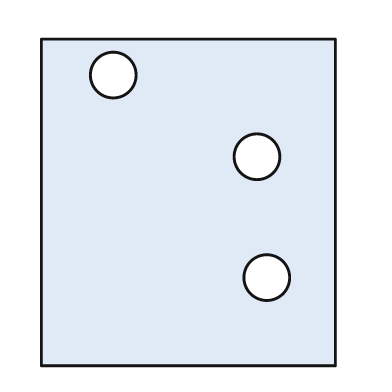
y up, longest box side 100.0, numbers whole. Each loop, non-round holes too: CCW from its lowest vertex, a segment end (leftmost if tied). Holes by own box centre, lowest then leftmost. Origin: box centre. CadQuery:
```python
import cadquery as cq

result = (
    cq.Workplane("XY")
    .moveTo(-45.0, -50.0)
    .lineTo(45.0, -50.0)
    .lineTo(45.0, 50.0)
    .lineTo(-45.0, 50.0)
    .close()
    .moveTo(24.0, -23.0)
    .circle(7.0)
    .moveTo(21.0, 14.0)
    .circle(7.0)
    .moveTo(-23.0, 39.0)
    .circle(7.0)
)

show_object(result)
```